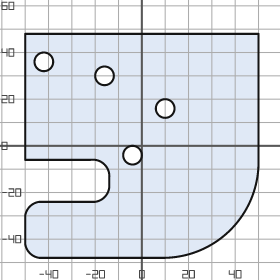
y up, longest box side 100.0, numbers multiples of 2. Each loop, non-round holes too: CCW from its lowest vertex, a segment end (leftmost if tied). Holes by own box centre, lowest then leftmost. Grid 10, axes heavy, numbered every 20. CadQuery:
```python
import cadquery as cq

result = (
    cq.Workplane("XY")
    .moveTo(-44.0, -48.0)
    .lineTo(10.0, -48.0)
    .threePointArc((38.0, -36.0), (50.0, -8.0))
    .lineTo(50.0, 48.0)
    .lineTo(-50.0, 48.0)
    .lineTo(-50.0, -6.0)
    .lineTo(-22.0, -6.0)
    .threePointArc((-16.0, -8.0), (-14.0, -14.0))
    .lineTo(-14.0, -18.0)
    .threePointArc((-16.0, -22.0), (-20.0, -24.0))
    .lineTo(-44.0, -24.0)
    .threePointArc((-48.0, -26.0), (-50.0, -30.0))
    .lineTo(-50.0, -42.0)
    .threePointArc((-48.0, -46.0), (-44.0, -48.0))
    .close()
    .moveTo(-4.0, -4.0)
    .circle(4.0)
    .moveTo(10.0, 16.0)
    .circle(4.0)
    .moveTo(-16.0, 30.0)
    .circle(4.0)
    .moveTo(-42.0, 36.0)
    .circle(4.0)
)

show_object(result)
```